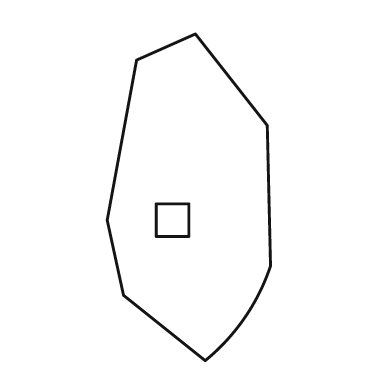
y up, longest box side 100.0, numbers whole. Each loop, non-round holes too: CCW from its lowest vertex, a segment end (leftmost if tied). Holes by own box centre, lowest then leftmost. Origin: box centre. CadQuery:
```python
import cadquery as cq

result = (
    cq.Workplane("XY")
    .moveTo(5.0, -50.0)
    .threePointArc((17.0, -37.0), (25.0, -21.0))
    .lineTo(24.0, 22.0)
    .lineTo(2.0, 50.0)
    .lineTo(-16.0, 42.0)
    .lineTo(-25.0, -7.0)
    .lineTo(-20.0, -30.0)
    .close()
    .moveTo(-10.0, -12.0)
    .lineTo(0.0, -12.0)
    .lineTo(0.0, -2.0)
    .lineTo(-10.0, -2.0)
    .close()
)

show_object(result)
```